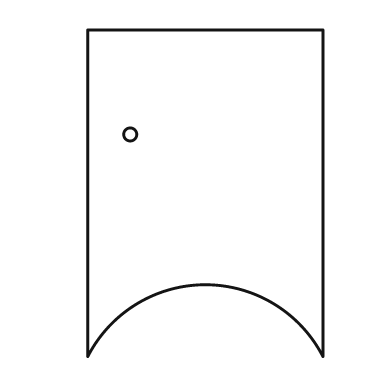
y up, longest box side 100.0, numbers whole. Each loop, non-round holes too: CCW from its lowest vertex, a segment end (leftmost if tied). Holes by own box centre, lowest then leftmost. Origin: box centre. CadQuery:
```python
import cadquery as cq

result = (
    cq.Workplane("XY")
    .moveTo(-36.0, -50.0)
    .threePointArc((0.0, -28.0), (36.0, -50.0))
    .lineTo(36.0, 50.0)
    .lineTo(-36.0, 50.0)
    .close()
    .moveTo(-23.0, 18.0)
    .circle(2.0)
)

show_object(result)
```